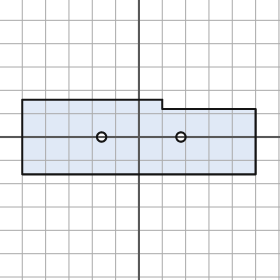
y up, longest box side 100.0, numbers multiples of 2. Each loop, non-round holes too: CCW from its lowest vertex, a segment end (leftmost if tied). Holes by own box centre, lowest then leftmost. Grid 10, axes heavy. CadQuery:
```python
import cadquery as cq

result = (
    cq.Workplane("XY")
    .moveTo(-50.0, -16.0)
    .lineTo(50.0, -16.0)
    .lineTo(50.0, 12.0)
    .lineTo(10.0, 12.0)
    .lineTo(10.0, 16.0)
    .lineTo(-50.0, 16.0)
    .close()
    .moveTo(-16.0, 0.0)
    .circle(2.0)
    .moveTo(18.0, 0.0)
    .circle(2.0)
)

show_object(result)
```